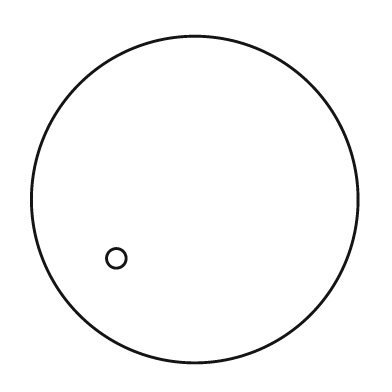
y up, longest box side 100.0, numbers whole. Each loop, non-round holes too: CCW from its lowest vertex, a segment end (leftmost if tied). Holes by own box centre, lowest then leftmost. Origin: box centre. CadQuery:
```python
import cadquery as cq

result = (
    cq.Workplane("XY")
    .moveTo(0.0, 0.0)
    .circle(50.0)
    .moveTo(-24.0, -18.0)
    .circle(3.0)
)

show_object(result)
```